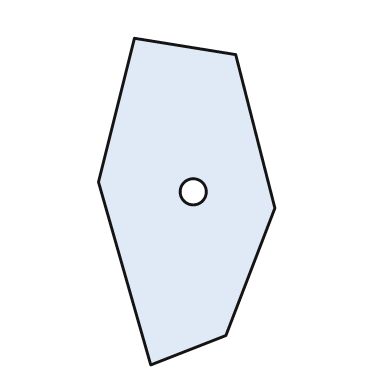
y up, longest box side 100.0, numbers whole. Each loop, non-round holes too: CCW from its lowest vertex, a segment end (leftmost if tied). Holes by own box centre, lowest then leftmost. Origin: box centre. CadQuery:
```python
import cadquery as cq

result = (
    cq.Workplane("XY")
    .moveTo(-11.0, -50.0)
    .lineTo(12.0, -41.0)
    .lineTo(27.0, -2.0)
    .lineTo(15.0, 45.0)
    .lineTo(-16.0, 50.0)
    .lineTo(-27.0, 6.0)
    .close()
    .moveTo(2.0, 3.0)
    .circle(4.0)
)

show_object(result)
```